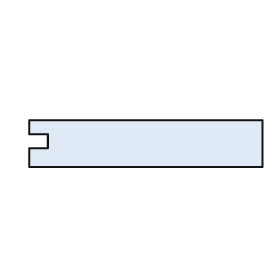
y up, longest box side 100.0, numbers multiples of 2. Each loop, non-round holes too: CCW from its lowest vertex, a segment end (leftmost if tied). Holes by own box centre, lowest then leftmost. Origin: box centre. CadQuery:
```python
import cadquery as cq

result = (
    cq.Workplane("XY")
    .moveTo(-50.0, -10.0)
    .lineTo(50.0, -10.0)
    .lineTo(50.0, 10.0)
    .lineTo(-50.0, 10.0)
    .lineTo(-50.0, 4.0)
    .lineTo(-42.0, 4.0)
    .lineTo(-42.0, -2.0)
    .lineTo(-50.0, -2.0)
    .close()
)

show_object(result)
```